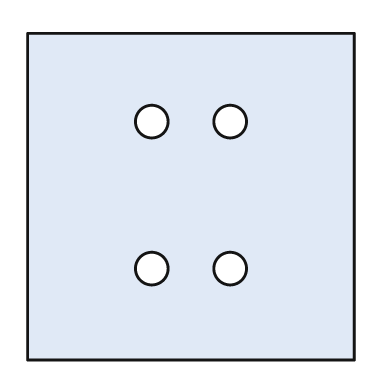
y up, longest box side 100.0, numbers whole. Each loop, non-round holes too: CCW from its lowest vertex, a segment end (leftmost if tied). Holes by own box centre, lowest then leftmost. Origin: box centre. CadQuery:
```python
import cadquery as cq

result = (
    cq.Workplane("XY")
    .moveTo(-50.0, -50.0)
    .lineTo(50.0, -50.0)
    .lineTo(50.0, 50.0)
    .lineTo(-50.0, 50.0)
    .close()
    .moveTo(-12.0, -22.0)
    .circle(5.0)
    .moveTo(12.0, -22.0)
    .circle(5.0)
    .moveTo(-12.0, 23.0)
    .circle(5.0)
    .moveTo(12.0, 23.0)
    .circle(5.0)
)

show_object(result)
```